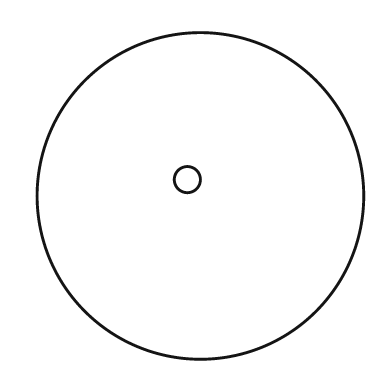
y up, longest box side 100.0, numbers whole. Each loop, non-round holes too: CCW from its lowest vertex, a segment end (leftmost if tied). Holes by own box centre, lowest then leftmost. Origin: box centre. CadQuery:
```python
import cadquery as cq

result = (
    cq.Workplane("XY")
    .moveTo(0.0, 0.0)
    .circle(50.0)
    .moveTo(-4.0, 5.0)
    .circle(4.0)
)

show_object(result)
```